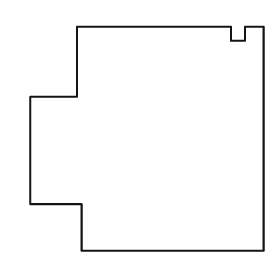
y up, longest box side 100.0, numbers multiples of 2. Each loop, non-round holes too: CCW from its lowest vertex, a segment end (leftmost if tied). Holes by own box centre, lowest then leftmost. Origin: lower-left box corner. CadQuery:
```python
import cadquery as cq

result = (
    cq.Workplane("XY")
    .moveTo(22.0, 0.0)
    .lineTo(100.0, 0.0)
    .lineTo(100.0, 96.0)
    .lineTo(92.0, 96.0)
    .lineTo(92.0, 90.0)
    .lineTo(86.0, 90.0)
    .lineTo(86.0, 96.0)
    .lineTo(20.0, 96.0)
    .lineTo(20.0, 66.0)
    .lineTo(0.0, 66.0)
    .lineTo(0.0, 20.0)
    .lineTo(22.0, 20.0)
    .close()
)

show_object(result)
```